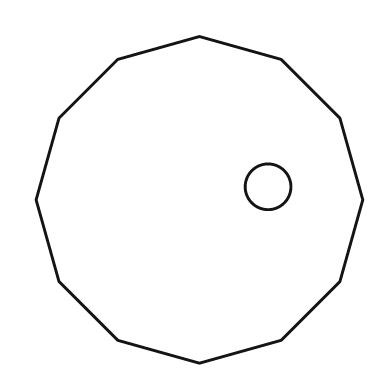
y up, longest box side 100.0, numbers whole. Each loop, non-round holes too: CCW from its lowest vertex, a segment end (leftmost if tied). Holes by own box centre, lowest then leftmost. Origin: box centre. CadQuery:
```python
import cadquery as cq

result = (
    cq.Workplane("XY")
    .moveTo(0.0, -50.0)
    .lineTo(25.0, -43.0)
    .lineTo(43.0, -25.0)
    .lineTo(50.0, 0.0)
    .lineTo(43.0, 25.0)
    .lineTo(25.0, 43.0)
    .lineTo(0.0, 50.0)
    .lineTo(-25.0, 43.0)
    .lineTo(-43.0, 25.0)
    .lineTo(-50.0, 0.0)
    .lineTo(-43.0, -25.0)
    .lineTo(-25.0, -43.0)
    .close()
    .moveTo(21.0, 4.0)
    .circle(7.0)
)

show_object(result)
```